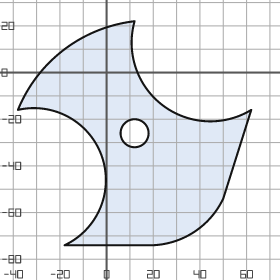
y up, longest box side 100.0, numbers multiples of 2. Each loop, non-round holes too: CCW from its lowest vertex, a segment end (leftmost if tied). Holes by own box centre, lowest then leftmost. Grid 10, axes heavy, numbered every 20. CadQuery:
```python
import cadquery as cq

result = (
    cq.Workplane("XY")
    .moveTo(-18.0, -74.0)
    .lineTo(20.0, -74.0)
    .threePointArc((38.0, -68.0), (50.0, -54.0))
    .lineTo(62.0, -16.0)
    .threePointArc((24.0, -14.0), (12.0, 22.0))
    .threePointArc((-18.0, 10.0), (-38.0, -16.0))
    .threePointArc((-2.0, -36.0), (-18.0, -74.0))
    .close()
    .moveTo(12.0, -26.0)
    .circle(6.0)
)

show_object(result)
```